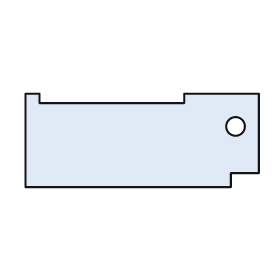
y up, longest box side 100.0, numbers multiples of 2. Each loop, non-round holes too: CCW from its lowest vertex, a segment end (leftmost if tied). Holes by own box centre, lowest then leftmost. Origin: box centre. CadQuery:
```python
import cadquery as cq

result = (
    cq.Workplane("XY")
    .moveTo(-50.0, -20.0)
    .lineTo(38.0, -20.0)
    .lineTo(38.0, -14.0)
    .lineTo(50.0, -14.0)
    .lineTo(50.0, 20.0)
    .lineTo(18.0, 20.0)
    .lineTo(18.0, 16.0)
    .lineTo(-44.0, 16.0)
    .lineTo(-44.0, 20.0)
    .lineTo(-50.0, 20.0)
    .close()
    .moveTo(40.0, 6.0)
    .circle(4.0)
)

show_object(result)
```